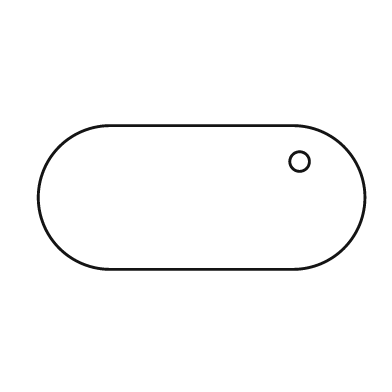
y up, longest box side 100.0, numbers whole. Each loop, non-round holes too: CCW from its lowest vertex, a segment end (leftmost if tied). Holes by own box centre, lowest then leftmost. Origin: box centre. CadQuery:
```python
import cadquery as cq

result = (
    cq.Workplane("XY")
    .moveTo(-28.0, -22.0)
    .lineTo(28.0, -22.0)
    .threePointArc((50.0, 0.0), (28.0, 22.0))
    .lineTo(-28.0, 22.0)
    .threePointArc((-50.0, 0.0), (-28.0, -22.0))
    .close()
    .moveTo(30.0, 11.0)
    .circle(3.0)
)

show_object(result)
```